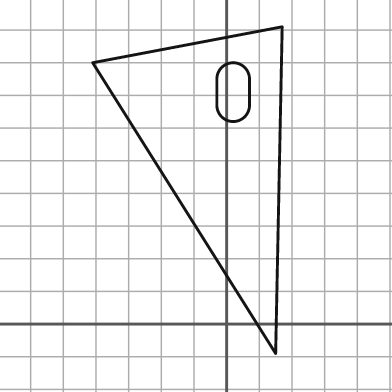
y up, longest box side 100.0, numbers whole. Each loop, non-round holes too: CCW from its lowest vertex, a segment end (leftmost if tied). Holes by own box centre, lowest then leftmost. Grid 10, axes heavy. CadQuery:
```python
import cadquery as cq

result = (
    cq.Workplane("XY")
    .moveTo(15.0, -9.0)
    .lineTo(17.0, 91.0)
    .lineTo(-41.0, 80.0)
    .close()
    .moveTo(-3.0, 67.0)
    .threePointArc((2.0, 62.0), (7.0, 67.0))
    .lineTo(7.0, 75.0)
    .threePointArc((2.0, 80.0), (-3.0, 75.0))
    .close()
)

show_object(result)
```